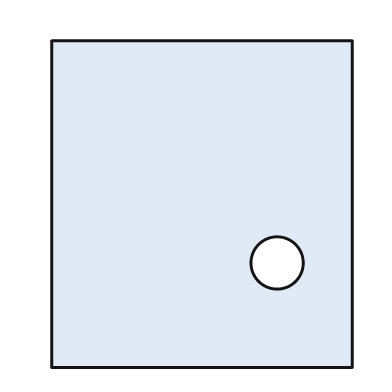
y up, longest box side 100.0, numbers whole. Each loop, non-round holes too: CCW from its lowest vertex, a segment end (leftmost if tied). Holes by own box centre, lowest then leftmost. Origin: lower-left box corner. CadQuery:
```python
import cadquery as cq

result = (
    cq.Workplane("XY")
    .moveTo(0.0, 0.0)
    .lineTo(92.0, 0.0)
    .lineTo(92.0, 100.0)
    .lineTo(0.0, 100.0)
    .close()
    .moveTo(69.0, 32.0)
    .circle(8.0)
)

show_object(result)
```